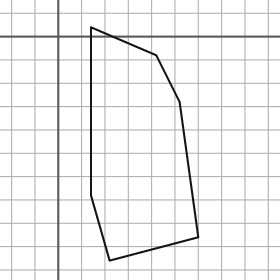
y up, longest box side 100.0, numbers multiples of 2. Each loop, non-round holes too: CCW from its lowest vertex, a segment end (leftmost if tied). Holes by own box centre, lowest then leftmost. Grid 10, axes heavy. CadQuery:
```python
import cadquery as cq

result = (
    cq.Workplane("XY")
    .moveTo(22.0, -96.0)
    .lineTo(60.0, -86.0)
    .lineTo(52.0, -28.0)
    .lineTo(42.0, -8.0)
    .lineTo(14.0, 4.0)
    .lineTo(14.0, -68.0)
    .close()
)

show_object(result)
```